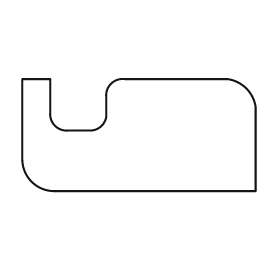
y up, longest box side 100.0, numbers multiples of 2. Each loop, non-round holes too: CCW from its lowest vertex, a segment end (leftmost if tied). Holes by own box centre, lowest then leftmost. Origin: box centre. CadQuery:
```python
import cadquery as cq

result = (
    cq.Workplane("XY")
    .moveTo(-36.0, -24.0)
    .lineTo(50.0, -24.0)
    .lineTo(50.0, 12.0)
    .threePointArc((46.0, 20.0), (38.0, 24.0))
    .lineTo(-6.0, 24.0)
    .threePointArc((-12.0, 22.0), (-14.0, 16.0))
    .lineTo(-14.0, 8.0)
    .threePointArc((-16.0, 4.0), (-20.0, 2.0))
    .lineTo(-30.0, 2.0)
    .threePointArc((-36.0, 4.0), (-38.0, 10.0))
    .lineTo(-38.0, 24.0)
    .lineTo(-50.0, 24.0)
    .lineTo(-50.0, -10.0)
    .threePointArc((-46.0, -20.0), (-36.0, -24.0))
    .close()
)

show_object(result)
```